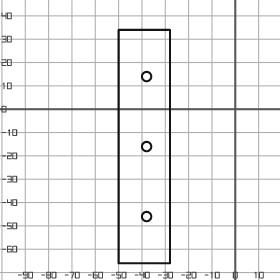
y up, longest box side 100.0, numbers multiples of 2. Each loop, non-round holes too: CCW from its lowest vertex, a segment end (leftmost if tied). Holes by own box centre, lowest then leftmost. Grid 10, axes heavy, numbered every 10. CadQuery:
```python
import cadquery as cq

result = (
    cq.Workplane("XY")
    .moveTo(-50.0, -66.0)
    .lineTo(-28.0, -66.0)
    .lineTo(-28.0, 34.0)
    .lineTo(-50.0, 34.0)
    .close()
    .moveTo(-38.0, -46.0)
    .circle(2.0)
    .moveTo(-38.0, -16.0)
    .circle(2.0)
    .moveTo(-38.0, 14.0)
    .circle(2.0)
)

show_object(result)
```